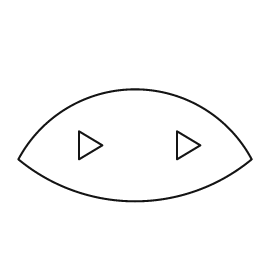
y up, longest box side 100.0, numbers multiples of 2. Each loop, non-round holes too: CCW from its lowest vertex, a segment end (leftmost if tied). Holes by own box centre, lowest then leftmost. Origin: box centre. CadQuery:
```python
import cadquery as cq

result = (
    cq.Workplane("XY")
    .moveTo(-50.0, -6.0)
    .threePointArc((0.0, -24.0), (50.0, -6.0))
    .threePointArc((0.0, 24.0), (-50.0, -6.0))
    .close()
    .moveTo(-24.0, -6.0)
    .lineTo(-14.0, 0.0)
    .lineTo(-24.0, 6.0)
    .close()
    .moveTo(18.0, -6.0)
    .lineTo(28.0, 0.0)
    .lineTo(18.0, 6.0)
    .close()
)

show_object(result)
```